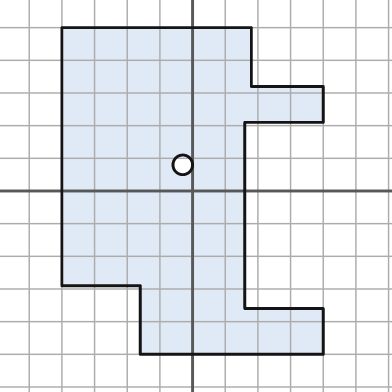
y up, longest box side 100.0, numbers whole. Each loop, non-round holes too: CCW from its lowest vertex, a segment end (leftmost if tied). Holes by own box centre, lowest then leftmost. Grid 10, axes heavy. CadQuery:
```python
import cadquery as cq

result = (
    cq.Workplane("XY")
    .moveTo(-16.0, -50.0)
    .lineTo(40.0, -50.0)
    .lineTo(40.0, -36.0)
    .lineTo(16.0, -36.0)
    .lineTo(16.0, 21.0)
    .lineTo(40.0, 21.0)
    .lineTo(40.0, 32.0)
    .lineTo(18.0, 32.0)
    .lineTo(18.0, 50.0)
    .lineTo(-40.0, 50.0)
    .lineTo(-40.0, -29.0)
    .lineTo(-16.0, -29.0)
    .close()
    .moveTo(-3.0, 8.0)
    .circle(3.0)
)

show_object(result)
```